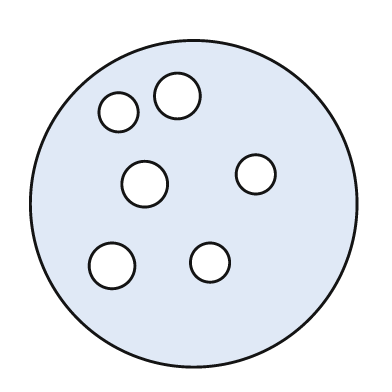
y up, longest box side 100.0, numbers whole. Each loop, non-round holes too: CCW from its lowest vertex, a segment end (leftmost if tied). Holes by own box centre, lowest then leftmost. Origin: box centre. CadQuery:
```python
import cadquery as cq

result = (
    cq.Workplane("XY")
    .moveTo(0.0, 0.0)
    .circle(50.0)
    .moveTo(-25.0, -19.0)
    .circle(7.0)
    .moveTo(5.0, -18.0)
    .circle(6.0)
    .moveTo(-15.0, 6.0)
    .circle(7.0)
    .moveTo(19.0, 9.0)
    .circle(6.0)
    .moveTo(-23.0, 28.0)
    .circle(6.0)
    .moveTo(-5.0, 33.0)
    .circle(7.0)
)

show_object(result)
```